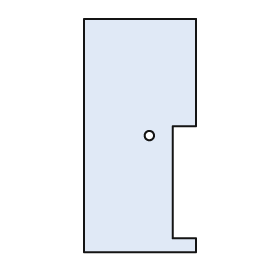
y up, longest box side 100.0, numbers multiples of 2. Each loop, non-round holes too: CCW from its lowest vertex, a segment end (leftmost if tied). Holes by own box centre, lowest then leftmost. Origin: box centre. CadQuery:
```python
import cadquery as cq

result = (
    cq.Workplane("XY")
    .moveTo(-24.0, -50.0)
    .lineTo(24.0, -50.0)
    .lineTo(24.0, -44.0)
    .lineTo(14.0, -44.0)
    .lineTo(14.0, 4.0)
    .lineTo(24.0, 4.0)
    .lineTo(24.0, 50.0)
    .lineTo(-24.0, 50.0)
    .close()
    .moveTo(4.0, 0.0)
    .circle(2.0)
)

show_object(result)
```